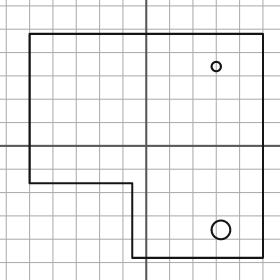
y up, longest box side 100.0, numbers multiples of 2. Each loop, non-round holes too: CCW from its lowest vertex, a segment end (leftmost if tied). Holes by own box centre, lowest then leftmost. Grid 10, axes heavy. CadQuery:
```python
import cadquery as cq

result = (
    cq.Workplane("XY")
    .moveTo(-6.0, -48.0)
    .lineTo(50.0, -48.0)
    .lineTo(50.0, 48.0)
    .lineTo(-50.0, 48.0)
    .lineTo(-50.0, -16.0)
    .lineTo(-6.0, -16.0)
    .close()
    .moveTo(32.0, -36.0)
    .circle(4.0)
    .moveTo(30.0, 34.0)
    .circle(2.0)
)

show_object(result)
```